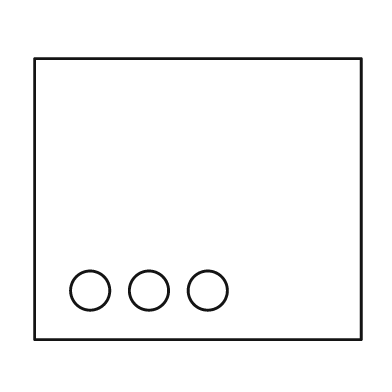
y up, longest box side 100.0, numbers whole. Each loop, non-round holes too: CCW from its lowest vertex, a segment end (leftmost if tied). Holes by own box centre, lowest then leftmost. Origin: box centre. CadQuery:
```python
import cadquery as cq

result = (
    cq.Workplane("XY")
    .moveTo(-50.0, -43.0)
    .lineTo(50.0, -43.0)
    .lineTo(50.0, 43.0)
    .lineTo(-50.0, 43.0)
    .close()
    .moveTo(-33.0, -28.0)
    .circle(6.0)
    .moveTo(-15.0, -28.0)
    .circle(6.0)
    .moveTo(3.0, -28.0)
    .circle(6.0)
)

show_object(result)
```